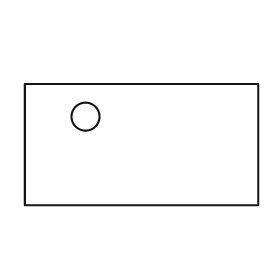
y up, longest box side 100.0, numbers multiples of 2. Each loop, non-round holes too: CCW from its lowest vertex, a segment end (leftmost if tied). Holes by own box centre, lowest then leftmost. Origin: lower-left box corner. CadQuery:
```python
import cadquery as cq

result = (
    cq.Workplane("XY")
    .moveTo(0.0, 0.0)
    .lineTo(100.0, 0.0)
    .lineTo(100.0, 52.0)
    .lineTo(0.0, 52.0)
    .close()
    .moveTo(26.0, 38.0)
    .circle(6.0)
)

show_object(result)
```